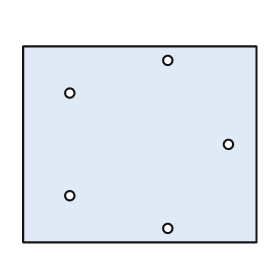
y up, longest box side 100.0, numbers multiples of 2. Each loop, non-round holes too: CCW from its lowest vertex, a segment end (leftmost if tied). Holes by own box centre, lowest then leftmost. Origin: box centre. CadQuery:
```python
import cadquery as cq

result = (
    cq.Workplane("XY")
    .moveTo(-50.0, -42.0)
    .lineTo(50.0, -42.0)
    .lineTo(50.0, 42.0)
    .lineTo(-50.0, 42.0)
    .close()
    .moveTo(12.0, -36.0)
    .circle(2.0)
    .moveTo(-30.0, -22.0)
    .circle(2.0)
    .moveTo(38.0, 0.0)
    .circle(2.0)
    .moveTo(-30.0, 22.0)
    .circle(2.0)
    .moveTo(12.0, 36.0)
    .circle(2.0)
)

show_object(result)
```